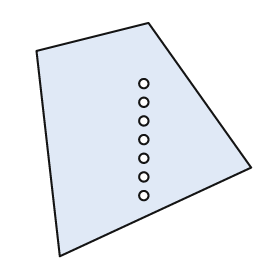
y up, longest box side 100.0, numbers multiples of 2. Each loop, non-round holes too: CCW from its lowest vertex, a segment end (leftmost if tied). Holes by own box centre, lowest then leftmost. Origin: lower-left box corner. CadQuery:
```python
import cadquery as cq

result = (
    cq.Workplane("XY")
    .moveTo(10.0, 0.0)
    .lineTo(92.0, 38.0)
    .lineTo(48.0, 100.0)
    .lineTo(0.0, 88.0)
    .close()
    .moveTo(46.0, 26.0)
    .circle(2.0)
    .moveTo(46.0, 34.0)
    .circle(2.0)
    .moveTo(46.0, 42.0)
    .circle(2.0)
    .moveTo(46.0, 50.0)
    .circle(2.0)
    .moveTo(46.0, 58.0)
    .circle(2.0)
    .moveTo(46.0, 66.0)
    .circle(2.0)
    .moveTo(46.0, 74.0)
    .circle(2.0)
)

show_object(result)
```